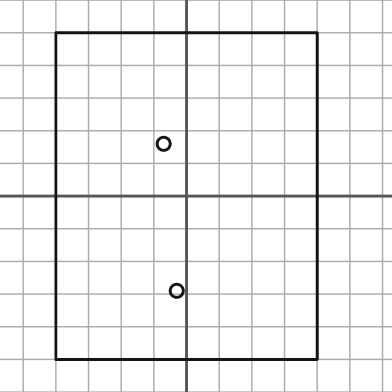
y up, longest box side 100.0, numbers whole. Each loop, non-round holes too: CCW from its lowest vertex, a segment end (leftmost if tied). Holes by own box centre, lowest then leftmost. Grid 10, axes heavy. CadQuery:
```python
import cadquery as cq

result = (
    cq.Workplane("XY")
    .moveTo(-40.0, -50.0)
    .lineTo(40.0, -50.0)
    .lineTo(40.0, 50.0)
    .lineTo(-40.0, 50.0)
    .close()
    .moveTo(-3.0, -29.0)
    .circle(2.0)
    .moveTo(-7.0, 16.0)
    .circle(2.0)
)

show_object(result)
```